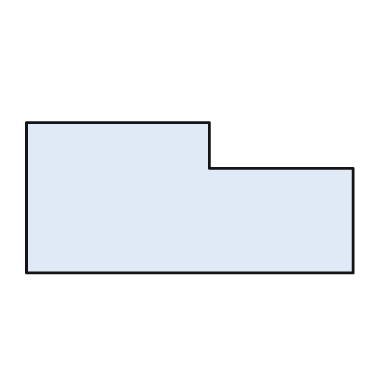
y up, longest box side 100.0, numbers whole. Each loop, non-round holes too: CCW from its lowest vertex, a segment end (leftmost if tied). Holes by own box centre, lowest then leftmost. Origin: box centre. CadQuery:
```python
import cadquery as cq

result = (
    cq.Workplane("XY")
    .moveTo(-50.0, -23.0)
    .lineTo(50.0, -23.0)
    .lineTo(50.0, 9.0)
    .lineTo(6.0, 9.0)
    .lineTo(6.0, 23.0)
    .lineTo(-50.0, 23.0)
    .close()
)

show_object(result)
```